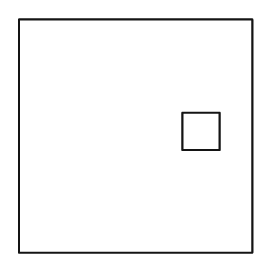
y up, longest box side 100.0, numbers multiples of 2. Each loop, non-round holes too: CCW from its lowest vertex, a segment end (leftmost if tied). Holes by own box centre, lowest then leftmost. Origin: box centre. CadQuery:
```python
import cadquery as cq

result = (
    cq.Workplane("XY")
    .moveTo(-50.0, -50.0)
    .lineTo(50.0, -50.0)
    .lineTo(50.0, 50.0)
    .lineTo(-50.0, 50.0)
    .close()
    .moveTo(20.0, -6.0)
    .lineTo(36.0, -6.0)
    .lineTo(36.0, 10.0)
    .lineTo(20.0, 10.0)
    .close()
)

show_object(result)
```